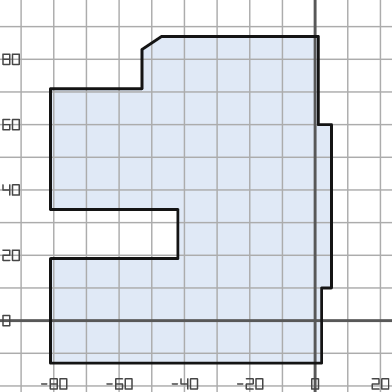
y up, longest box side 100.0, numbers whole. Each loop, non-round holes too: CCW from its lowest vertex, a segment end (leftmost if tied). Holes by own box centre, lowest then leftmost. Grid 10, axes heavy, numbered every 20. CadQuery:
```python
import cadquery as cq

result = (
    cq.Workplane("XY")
    .moveTo(-81.0, -13.0)
    .lineTo(2.0, -13.0)
    .lineTo(2.0, 10.0)
    .lineTo(5.0, 10.0)
    .lineTo(5.0, 60.0)
    .lineTo(1.0, 60.0)
    .lineTo(1.0, 87.0)
    .lineTo(-47.0, 87.0)
    .lineTo(-53.0, 83.0)
    .lineTo(-53.0, 71.0)
    .lineTo(-81.0, 71.0)
    .lineTo(-81.0, 34.0)
    .lineTo(-42.0, 34.0)
    .lineTo(-42.0, 19.0)
    .lineTo(-81.0, 19.0)
    .close()
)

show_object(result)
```